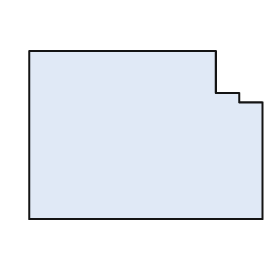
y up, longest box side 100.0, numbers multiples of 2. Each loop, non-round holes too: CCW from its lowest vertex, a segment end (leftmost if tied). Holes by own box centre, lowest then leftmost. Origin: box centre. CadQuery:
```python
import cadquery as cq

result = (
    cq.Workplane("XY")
    .moveTo(-50.0, -36.0)
    .lineTo(50.0, -36.0)
    .lineTo(50.0, 14.0)
    .lineTo(40.0, 14.0)
    .lineTo(40.0, 18.0)
    .lineTo(30.0, 18.0)
    .lineTo(30.0, 36.0)
    .lineTo(-50.0, 36.0)
    .close()
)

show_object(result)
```